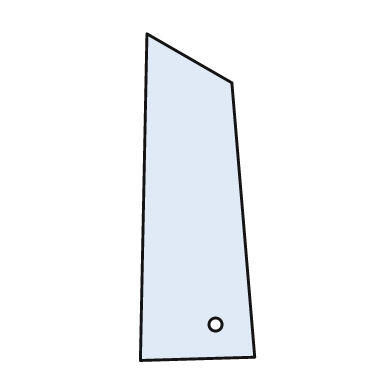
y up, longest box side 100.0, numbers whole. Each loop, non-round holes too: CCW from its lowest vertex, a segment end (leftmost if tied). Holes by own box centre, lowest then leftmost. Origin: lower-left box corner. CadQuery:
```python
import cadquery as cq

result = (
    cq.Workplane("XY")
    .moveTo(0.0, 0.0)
    .lineTo(35.0, 1.0)
    .lineTo(28.0, 85.0)
    .lineTo(2.0, 100.0)
    .close()
    .moveTo(23.0, 11.0)
    .circle(2.0)
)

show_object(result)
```